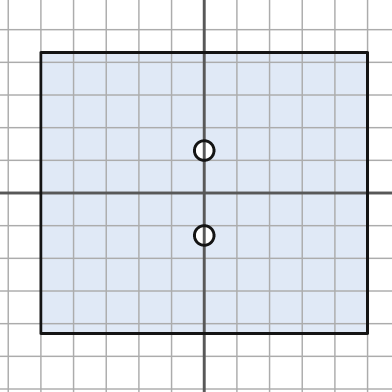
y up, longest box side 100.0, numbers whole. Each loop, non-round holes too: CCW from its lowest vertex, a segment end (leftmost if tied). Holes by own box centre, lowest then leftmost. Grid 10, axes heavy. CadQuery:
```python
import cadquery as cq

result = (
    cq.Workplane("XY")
    .moveTo(-50.0, -43.0)
    .lineTo(50.0, -43.0)
    .lineTo(50.0, 43.0)
    .lineTo(-50.0, 43.0)
    .close()
    .moveTo(0.0, -13.0)
    .circle(3.0)
    .moveTo(0.0, 13.0)
    .circle(3.0)
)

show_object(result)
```